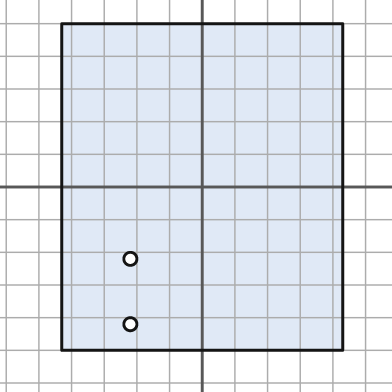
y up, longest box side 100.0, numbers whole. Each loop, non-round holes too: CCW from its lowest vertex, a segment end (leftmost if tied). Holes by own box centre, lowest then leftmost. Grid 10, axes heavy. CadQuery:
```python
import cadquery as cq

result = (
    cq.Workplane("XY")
    .moveTo(-43.0, -50.0)
    .lineTo(43.0, -50.0)
    .lineTo(43.0, 50.0)
    .lineTo(-43.0, 50.0)
    .close()
    .moveTo(-22.0, -42.0)
    .circle(2.0)
    .moveTo(-22.0, -22.0)
    .circle(2.0)
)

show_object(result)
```